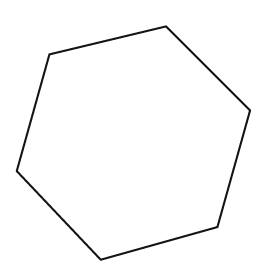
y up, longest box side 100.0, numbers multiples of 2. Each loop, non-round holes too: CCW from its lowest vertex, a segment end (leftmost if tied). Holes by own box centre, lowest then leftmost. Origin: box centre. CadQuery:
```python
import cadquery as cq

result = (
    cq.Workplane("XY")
    .moveTo(-14.0, -50.0)
    .lineTo(36.0, -36.0)
    .lineTo(50.0, 14.0)
    .lineTo(14.0, 50.0)
    .lineTo(-36.0, 38.0)
    .lineTo(-50.0, -12.0)
    .close()
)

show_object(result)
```